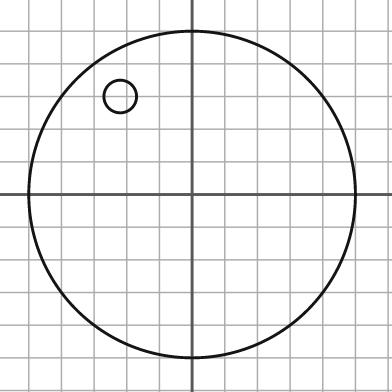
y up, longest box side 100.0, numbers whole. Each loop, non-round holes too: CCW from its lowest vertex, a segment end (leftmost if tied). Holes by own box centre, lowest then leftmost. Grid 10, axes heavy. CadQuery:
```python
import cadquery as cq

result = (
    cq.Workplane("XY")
    .moveTo(0.0, 0.0)
    .circle(50.0)
    .moveTo(-22.0, 30.0)
    .circle(5.0)
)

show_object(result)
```